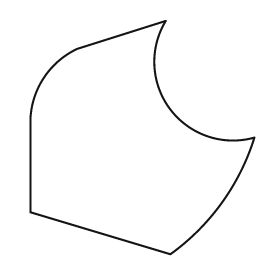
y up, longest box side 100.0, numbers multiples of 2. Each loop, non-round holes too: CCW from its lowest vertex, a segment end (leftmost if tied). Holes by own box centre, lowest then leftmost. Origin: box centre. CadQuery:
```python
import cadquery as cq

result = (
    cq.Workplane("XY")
    .moveTo(12.0, -50.0)
    .threePointArc((34.0, -28.0), (48.0, 0.0))
    .threePointArc((12.0, 12.0), (10.0, 50.0))
    .lineTo(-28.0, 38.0)
    .threePointArc((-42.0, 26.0), (-48.0, 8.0))
    .lineTo(-48.0, -32.0)
    .close()
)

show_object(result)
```